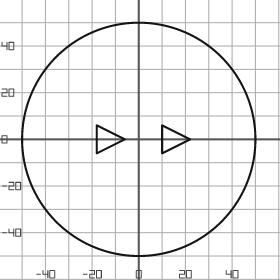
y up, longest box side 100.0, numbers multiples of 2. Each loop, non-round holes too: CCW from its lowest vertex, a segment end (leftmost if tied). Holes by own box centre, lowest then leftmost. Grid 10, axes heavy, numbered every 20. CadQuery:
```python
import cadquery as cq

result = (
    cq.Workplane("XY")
    .moveTo(0.0, 0.0)
    .circle(50.0)
    .moveTo(-18.0, -6.0)
    .lineTo(-6.0, 0.0)
    .lineTo(-18.0, 6.0)
    .close()
    .moveTo(10.0, -6.0)
    .lineTo(22.0, 0.0)
    .lineTo(10.0, 6.0)
    .close()
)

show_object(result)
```